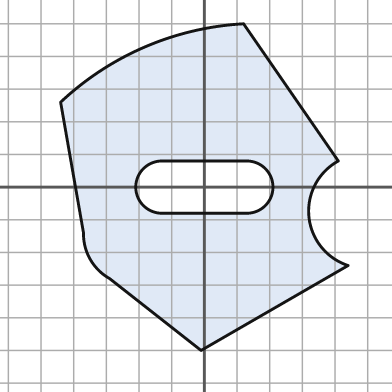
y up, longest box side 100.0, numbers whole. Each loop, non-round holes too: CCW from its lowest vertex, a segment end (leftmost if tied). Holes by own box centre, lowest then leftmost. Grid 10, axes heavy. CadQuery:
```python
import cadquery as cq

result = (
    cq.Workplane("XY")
    .moveTo(-1.0, -50.0)
    .lineTo(44.0, -24.0)
    .threePointArc((32.0, -9.0), (41.0, 8.0))
    .lineTo(12.0, 50.0)
    .threePointArc((-18.0, 43.0), (-44.0, 26.0))
    .lineTo(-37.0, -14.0)
    .threePointArc((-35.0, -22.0), (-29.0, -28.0))
    .close()
    .moveTo(-13.0, -8.0)
    .lineTo(13.0, -8.0)
    .threePointArc((21.0, 0.0), (13.0, 8.0))
    .lineTo(-13.0, 8.0)
    .threePointArc((-21.0, 0.0), (-13.0, -8.0))
    .close()
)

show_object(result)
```